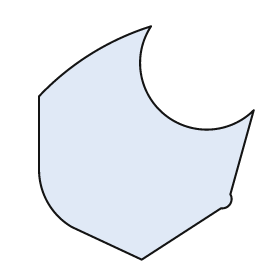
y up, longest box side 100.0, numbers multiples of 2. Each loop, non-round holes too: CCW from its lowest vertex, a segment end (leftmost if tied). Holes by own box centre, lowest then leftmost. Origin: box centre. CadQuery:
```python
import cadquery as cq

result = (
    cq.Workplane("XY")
    .moveTo(-2.0, -50.0)
    .lineTo(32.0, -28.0)
    .threePointArc((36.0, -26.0), (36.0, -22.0))
    .lineTo(46.0, 14.0)
    .threePointArc((8.0, 12.0), (2.0, 50.0))
    .threePointArc((-24.0, 38.0), (-46.0, 20.0))
    .lineTo(-46.0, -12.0)
    .threePointArc((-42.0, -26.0), (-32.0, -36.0))
    .close()
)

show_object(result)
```